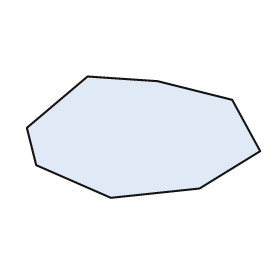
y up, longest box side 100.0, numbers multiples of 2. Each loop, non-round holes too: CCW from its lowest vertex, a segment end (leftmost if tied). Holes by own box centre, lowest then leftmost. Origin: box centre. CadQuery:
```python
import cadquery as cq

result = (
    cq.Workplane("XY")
    .moveTo(-14.0, -26.0)
    .lineTo(24.0, -22.0)
    .lineTo(50.0, -6.0)
    .lineTo(38.0, 16.0)
    .lineTo(6.0, 24.0)
    .lineTo(-24.0, 26.0)
    .lineTo(-50.0, 4.0)
    .lineTo(-46.0, -12.0)
    .close()
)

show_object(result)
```